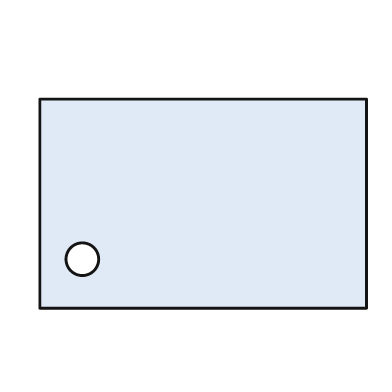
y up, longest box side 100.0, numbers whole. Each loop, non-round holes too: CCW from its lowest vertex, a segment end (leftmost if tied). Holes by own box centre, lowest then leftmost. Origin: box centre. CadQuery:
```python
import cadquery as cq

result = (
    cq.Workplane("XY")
    .moveTo(-50.0, -32.0)
    .lineTo(50.0, -32.0)
    .lineTo(50.0, 32.0)
    .lineTo(-50.0, 32.0)
    .close()
    .moveTo(-37.0, -17.0)
    .circle(5.0)
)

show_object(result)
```